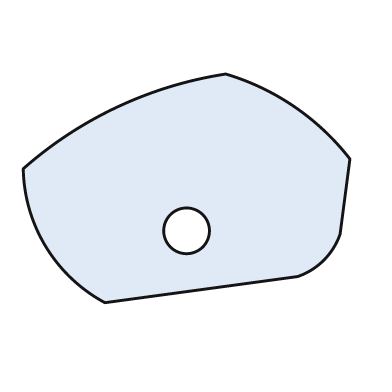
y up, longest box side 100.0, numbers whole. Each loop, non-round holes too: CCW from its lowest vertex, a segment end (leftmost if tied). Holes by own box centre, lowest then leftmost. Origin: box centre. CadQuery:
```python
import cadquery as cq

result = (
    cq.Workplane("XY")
    .moveTo(-25.0, -35.0)
    .lineTo(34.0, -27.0)
    .threePointArc((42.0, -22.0), (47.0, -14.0))
    .lineTo(50.0, 9.0)
    .threePointArc((33.0, 25.0), (12.0, 35.0))
    .threePointArc((-21.0, 25.0), (-50.0, 6.0))
    .threePointArc((-43.0, -18.0), (-25.0, -35.0))
    .close()
    .moveTo(0.0, -13.0)
    .circle(7.0)
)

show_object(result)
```